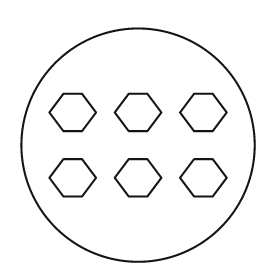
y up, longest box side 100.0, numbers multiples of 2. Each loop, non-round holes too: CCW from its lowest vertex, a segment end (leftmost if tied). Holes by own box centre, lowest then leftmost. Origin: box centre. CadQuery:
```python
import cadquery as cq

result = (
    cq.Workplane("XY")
    .moveTo(0.0, 0.0)
    .circle(50.0)
    .moveTo(-32.0, -22.0)
    .lineTo(-24.0, -22.0)
    .lineTo(-18.0, -14.0)
    .lineTo(-24.0, -6.0)
    .lineTo(-32.0, -6.0)
    .lineTo(-38.0, -14.0)
    .close()
    .moveTo(-4.0, -22.0)
    .lineTo(4.0, -22.0)
    .lineTo(10.0, -14.0)
    .lineTo(4.0, -6.0)
    .lineTo(-4.0, -6.0)
    .lineTo(-10.0, -14.0)
    .close()
    .moveTo(24.0, -22.0)
    .lineTo(32.0, -22.0)
    .lineTo(38.0, -14.0)
    .lineTo(32.0, -6.0)
    .lineTo(24.0, -6.0)
    .lineTo(18.0, -14.0)
    .close()
    .moveTo(-32.0, 6.0)
    .lineTo(-24.0, 6.0)
    .lineTo(-18.0, 14.0)
    .lineTo(-24.0, 22.0)
    .lineTo(-32.0, 22.0)
    .lineTo(-38.0, 14.0)
    .close()
    .moveTo(-4.0, 6.0)
    .lineTo(4.0, 6.0)
    .lineTo(10.0, 14.0)
    .lineTo(4.0, 22.0)
    .lineTo(-4.0, 22.0)
    .lineTo(-10.0, 14.0)
    .close()
    .moveTo(24.0, 6.0)
    .lineTo(32.0, 6.0)
    .lineTo(38.0, 14.0)
    .lineTo(32.0, 22.0)
    .lineTo(24.0, 22.0)
    .lineTo(18.0, 14.0)
    .close()
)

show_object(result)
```